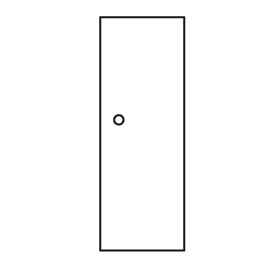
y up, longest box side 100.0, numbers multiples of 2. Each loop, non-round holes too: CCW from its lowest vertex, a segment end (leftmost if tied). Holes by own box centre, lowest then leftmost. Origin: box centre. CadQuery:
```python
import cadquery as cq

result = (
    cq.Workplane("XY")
    .moveTo(-18.0, -50.0)
    .lineTo(18.0, -50.0)
    .lineTo(18.0, 50.0)
    .lineTo(-18.0, 50.0)
    .close()
    .moveTo(-10.0, 6.0)
    .circle(2.0)
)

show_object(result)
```